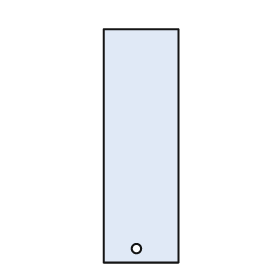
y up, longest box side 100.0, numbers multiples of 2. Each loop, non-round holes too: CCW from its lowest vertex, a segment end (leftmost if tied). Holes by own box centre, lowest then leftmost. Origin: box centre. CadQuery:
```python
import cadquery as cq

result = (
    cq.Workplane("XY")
    .moveTo(-16.0, -50.0)
    .lineTo(16.0, -50.0)
    .lineTo(16.0, 50.0)
    .lineTo(-16.0, 50.0)
    .close()
    .moveTo(-2.0, -44.0)
    .circle(2.0)
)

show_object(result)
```